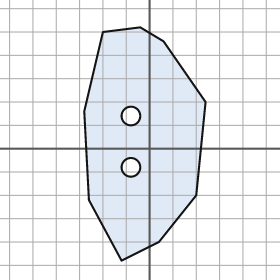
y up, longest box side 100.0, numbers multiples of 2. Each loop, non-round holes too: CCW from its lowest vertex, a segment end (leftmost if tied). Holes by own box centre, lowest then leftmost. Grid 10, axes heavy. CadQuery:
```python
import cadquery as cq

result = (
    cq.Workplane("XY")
    .moveTo(-12.0, -48.0)
    .lineTo(4.0, -40.0)
    .lineTo(20.0, -20.0)
    .lineTo(24.0, 20.0)
    .lineTo(6.0, 46.0)
    .lineTo(-4.0, 52.0)
    .lineTo(-20.0, 50.0)
    .lineTo(-28.0, 16.0)
    .lineTo(-26.0, -22.0)
    .close()
    .moveTo(-8.0, -8.0)
    .circle(4.0)
    .moveTo(-8.0, 14.0)
    .circle(4.0)
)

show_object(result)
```